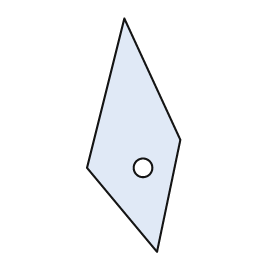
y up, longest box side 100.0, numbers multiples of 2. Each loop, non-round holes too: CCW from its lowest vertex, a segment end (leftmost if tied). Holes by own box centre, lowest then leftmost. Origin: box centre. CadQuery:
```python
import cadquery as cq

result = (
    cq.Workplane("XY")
    .moveTo(10.0, -50.0)
    .lineTo(20.0, -2.0)
    .lineTo(-4.0, 50.0)
    .lineTo(-20.0, -14.0)
    .close()
    .moveTo(4.0, -14.0)
    .circle(4.0)
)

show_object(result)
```